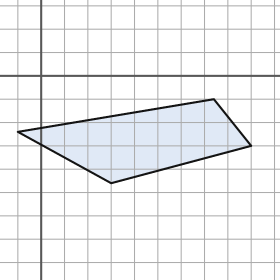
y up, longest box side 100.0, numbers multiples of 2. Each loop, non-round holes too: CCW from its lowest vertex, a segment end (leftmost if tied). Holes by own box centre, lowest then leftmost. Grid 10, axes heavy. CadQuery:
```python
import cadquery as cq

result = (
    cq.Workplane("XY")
    .moveTo(30.0, -46.0)
    .lineTo(90.0, -30.0)
    .lineTo(74.0, -10.0)
    .lineTo(-10.0, -24.0)
    .close()
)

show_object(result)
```